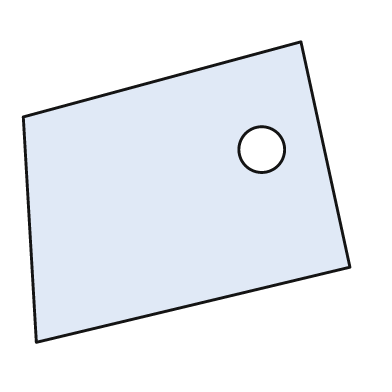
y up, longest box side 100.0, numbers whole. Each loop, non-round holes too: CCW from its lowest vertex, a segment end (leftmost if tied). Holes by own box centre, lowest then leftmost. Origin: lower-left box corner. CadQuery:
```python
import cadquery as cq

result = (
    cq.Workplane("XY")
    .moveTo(4.0, 0.0)
    .lineTo(100.0, 23.0)
    .lineTo(85.0, 92.0)
    .lineTo(0.0, 69.0)
    .close()
    .moveTo(73.0, 59.0)
    .circle(7.0)
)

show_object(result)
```